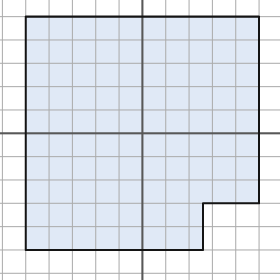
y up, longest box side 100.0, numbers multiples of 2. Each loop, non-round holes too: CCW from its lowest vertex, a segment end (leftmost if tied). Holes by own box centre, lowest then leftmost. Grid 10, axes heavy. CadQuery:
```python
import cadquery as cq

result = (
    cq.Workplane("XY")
    .moveTo(-50.0, -50.0)
    .lineTo(26.0, -50.0)
    .lineTo(26.0, -30.0)
    .lineTo(50.0, -30.0)
    .lineTo(50.0, 50.0)
    .lineTo(-50.0, 50.0)
    .close()
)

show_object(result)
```